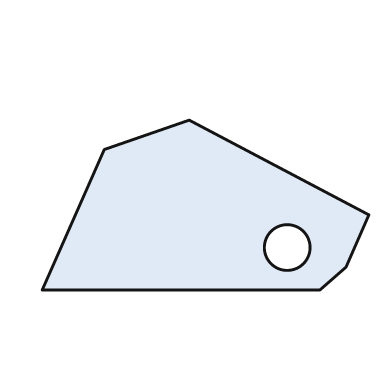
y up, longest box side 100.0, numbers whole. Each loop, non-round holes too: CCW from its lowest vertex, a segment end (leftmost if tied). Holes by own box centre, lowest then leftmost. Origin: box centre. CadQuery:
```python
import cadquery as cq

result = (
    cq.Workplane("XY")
    .moveTo(-50.0, -26.0)
    .lineTo(35.0, -26.0)
    .lineTo(43.0, -19.0)
    .lineTo(50.0, -3.0)
    .lineTo(-5.0, 26.0)
    .lineTo(-31.0, 17.0)
    .close()
    .moveTo(25.0, -13.0)
    .circle(7.0)
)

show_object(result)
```